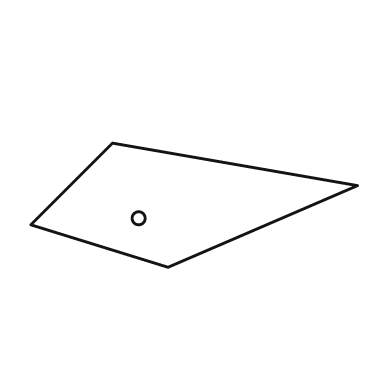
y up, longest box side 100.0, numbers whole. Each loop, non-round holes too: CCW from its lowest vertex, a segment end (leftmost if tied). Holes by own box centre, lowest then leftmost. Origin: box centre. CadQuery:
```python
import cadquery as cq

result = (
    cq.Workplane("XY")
    .moveTo(-8.0, -19.0)
    .lineTo(50.0, 6.0)
    .lineTo(-25.0, 19.0)
    .lineTo(-50.0, -6.0)
    .close()
    .moveTo(-17.0, -4.0)
    .circle(2.0)
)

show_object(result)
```